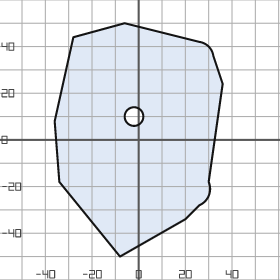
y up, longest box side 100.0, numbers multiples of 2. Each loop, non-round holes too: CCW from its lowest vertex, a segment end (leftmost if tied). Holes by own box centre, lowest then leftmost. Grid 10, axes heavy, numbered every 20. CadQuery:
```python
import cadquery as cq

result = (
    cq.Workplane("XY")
    .moveTo(-8.0, -50.0)
    .lineTo(20.0, -34.0)
    .lineTo(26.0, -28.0)
    .threePointArc((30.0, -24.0), (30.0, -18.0))
    .lineTo(36.0, 24.0)
    .lineTo(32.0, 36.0)
    .threePointArc((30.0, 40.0), (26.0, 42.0))
    .lineTo(-6.0, 50.0)
    .lineTo(-28.0, 44.0)
    .lineTo(-36.0, 8.0)
    .lineTo(-34.0, -18.0)
    .close()
    .moveTo(-2.0, 10.0)
    .circle(4.0)
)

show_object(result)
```